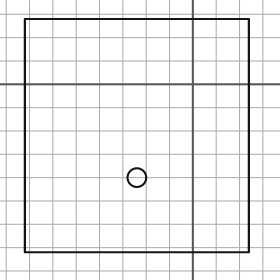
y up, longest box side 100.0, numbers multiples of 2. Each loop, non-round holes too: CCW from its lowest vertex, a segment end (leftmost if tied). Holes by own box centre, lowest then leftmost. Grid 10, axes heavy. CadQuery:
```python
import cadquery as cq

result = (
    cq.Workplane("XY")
    .moveTo(-72.0, -72.0)
    .lineTo(24.0, -72.0)
    .lineTo(24.0, 28.0)
    .lineTo(-72.0, 28.0)
    .close()
    .moveTo(-24.0, -40.0)
    .circle(4.0)
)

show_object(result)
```